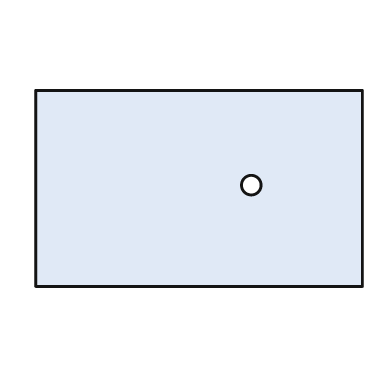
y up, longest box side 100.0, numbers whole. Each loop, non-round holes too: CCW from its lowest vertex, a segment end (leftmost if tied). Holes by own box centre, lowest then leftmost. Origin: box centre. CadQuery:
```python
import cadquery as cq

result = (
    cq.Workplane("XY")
    .moveTo(-50.0, -30.0)
    .lineTo(50.0, -30.0)
    .lineTo(50.0, 30.0)
    .lineTo(-50.0, 30.0)
    .close()
    .moveTo(16.0, 1.0)
    .circle(3.0)
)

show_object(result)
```